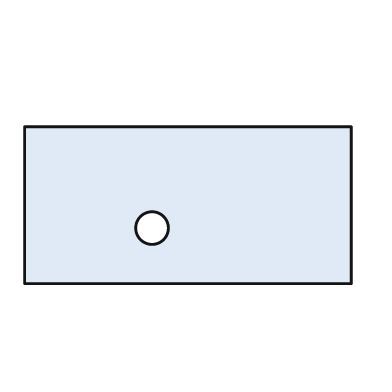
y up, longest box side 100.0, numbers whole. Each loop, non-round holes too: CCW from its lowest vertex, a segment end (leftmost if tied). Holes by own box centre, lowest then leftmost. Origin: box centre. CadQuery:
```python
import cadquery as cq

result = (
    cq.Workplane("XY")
    .moveTo(-50.0, -24.0)
    .lineTo(50.0, -24.0)
    .lineTo(50.0, 24.0)
    .lineTo(-50.0, 24.0)
    .close()
    .moveTo(-11.0, -7.0)
    .circle(5.0)
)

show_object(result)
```